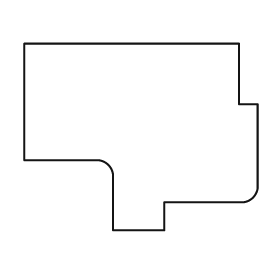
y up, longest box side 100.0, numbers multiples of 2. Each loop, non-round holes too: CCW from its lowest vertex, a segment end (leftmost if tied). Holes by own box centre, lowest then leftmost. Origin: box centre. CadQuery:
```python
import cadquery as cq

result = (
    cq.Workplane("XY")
    .moveTo(-12.0, -40.0)
    .lineTo(10.0, -40.0)
    .lineTo(10.0, -28.0)
    .lineTo(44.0, -28.0)
    .threePointArc((48.0, -26.0), (50.0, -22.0))
    .lineTo(50.0, 14.0)
    .lineTo(42.0, 14.0)
    .lineTo(42.0, 40.0)
    .lineTo(-50.0, 40.0)
    .lineTo(-50.0, -10.0)
    .lineTo(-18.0, -10.0)
    .threePointArc((-14.0, -12.0), (-12.0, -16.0))
    .close()
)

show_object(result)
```